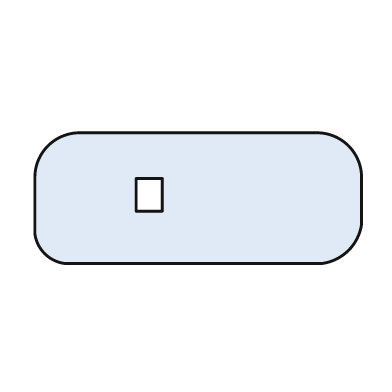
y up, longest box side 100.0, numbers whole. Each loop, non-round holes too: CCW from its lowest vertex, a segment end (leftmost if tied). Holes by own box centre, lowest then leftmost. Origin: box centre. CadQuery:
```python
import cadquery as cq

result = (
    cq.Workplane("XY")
    .moveTo(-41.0, -20.0)
    .lineTo(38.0, -20.0)
    .threePointArc((46.0, -16.0), (50.0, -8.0))
    .lineTo(50.0, 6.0)
    .threePointArc((46.0, 16.0), (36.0, 20.0))
    .lineTo(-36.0, 20.0)
    .threePointArc((-46.0, 16.0), (-50.0, 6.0))
    .lineTo(-50.0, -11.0)
    .threePointArc((-47.0, -17.0), (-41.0, -20.0))
    .close()
    .moveTo(-19.0, -4.0)
    .lineTo(-11.0, -4.0)
    .lineTo(-11.0, 6.0)
    .lineTo(-19.0, 6.0)
    .close()
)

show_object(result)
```